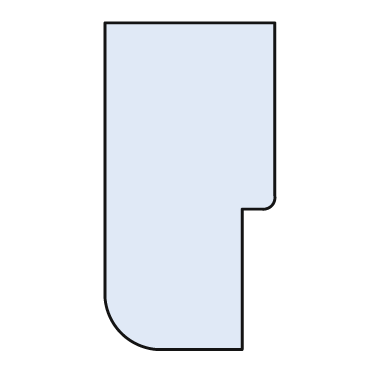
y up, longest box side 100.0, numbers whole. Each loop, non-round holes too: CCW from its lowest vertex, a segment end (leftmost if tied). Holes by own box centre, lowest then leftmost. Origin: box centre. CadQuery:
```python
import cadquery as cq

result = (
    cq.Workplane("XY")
    .moveTo(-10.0, -50.0)
    .lineTo(16.0, -50.0)
    .lineTo(16.0, -7.0)
    .lineTo(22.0, -7.0)
    .threePointArc((25.0, -6.0), (26.0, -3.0))
    .lineTo(26.0, 50.0)
    .lineTo(-26.0, 50.0)
    .lineTo(-26.0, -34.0)
    .threePointArc((-21.0, -45.0), (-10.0, -50.0))
    .close()
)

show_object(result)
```